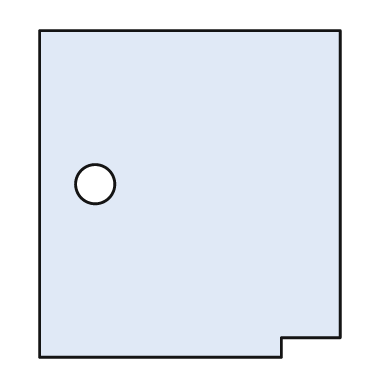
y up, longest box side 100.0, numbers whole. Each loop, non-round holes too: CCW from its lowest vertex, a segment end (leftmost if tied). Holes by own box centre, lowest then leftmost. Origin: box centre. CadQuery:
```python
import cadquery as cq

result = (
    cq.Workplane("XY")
    .moveTo(-46.0, -50.0)
    .lineTo(28.0, -50.0)
    .lineTo(28.0, -44.0)
    .lineTo(46.0, -44.0)
    .lineTo(46.0, 50.0)
    .lineTo(-46.0, 50.0)
    .close()
    .moveTo(-29.0, 3.0)
    .circle(6.0)
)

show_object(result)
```